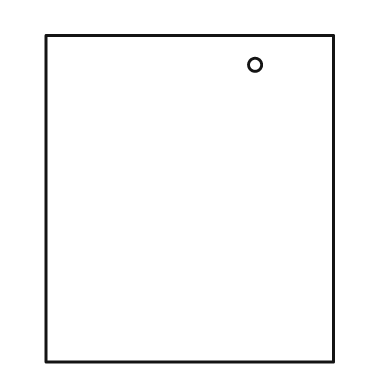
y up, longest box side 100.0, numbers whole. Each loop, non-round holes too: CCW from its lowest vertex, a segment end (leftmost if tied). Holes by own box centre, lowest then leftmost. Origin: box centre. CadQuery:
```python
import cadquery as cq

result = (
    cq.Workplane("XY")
    .moveTo(-44.0, -50.0)
    .lineTo(44.0, -50.0)
    .lineTo(44.0, 50.0)
    .lineTo(-44.0, 50.0)
    .close()
    .moveTo(20.0, 41.0)
    .circle(2.0)
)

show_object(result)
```